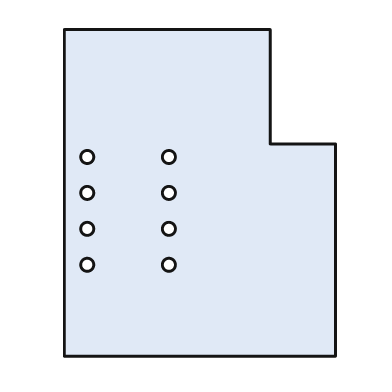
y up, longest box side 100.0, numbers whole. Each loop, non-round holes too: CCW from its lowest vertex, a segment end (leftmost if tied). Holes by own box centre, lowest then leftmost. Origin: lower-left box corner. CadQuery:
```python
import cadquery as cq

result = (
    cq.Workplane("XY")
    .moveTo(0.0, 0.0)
    .lineTo(83.0, 0.0)
    .lineTo(83.0, 65.0)
    .lineTo(63.0, 65.0)
    .lineTo(63.0, 100.0)
    .lineTo(0.0, 100.0)
    .close()
    .moveTo(7.0, 28.0)
    .circle(2.0)
    .moveTo(32.0, 28.0)
    .circle(2.0)
    .moveTo(7.0, 39.0)
    .circle(2.0)
    .moveTo(32.0, 39.0)
    .circle(2.0)
    .moveTo(7.0, 50.0)
    .circle(2.0)
    .moveTo(32.0, 50.0)
    .circle(2.0)
    .moveTo(7.0, 61.0)
    .circle(2.0)
    .moveTo(32.0, 61.0)
    .circle(2.0)
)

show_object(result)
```